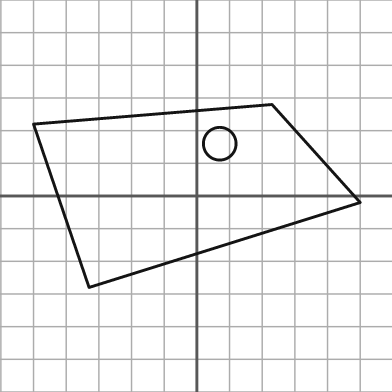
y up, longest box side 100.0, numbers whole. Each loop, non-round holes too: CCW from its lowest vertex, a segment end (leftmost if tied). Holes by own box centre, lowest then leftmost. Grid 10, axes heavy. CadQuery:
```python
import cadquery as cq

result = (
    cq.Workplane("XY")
    .moveTo(-33.0, -28.0)
    .lineTo(50.0, -2.0)
    .lineTo(23.0, 28.0)
    .lineTo(-50.0, 22.0)
    .close()
    .moveTo(7.0, 16.0)
    .circle(5.0)
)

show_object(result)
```